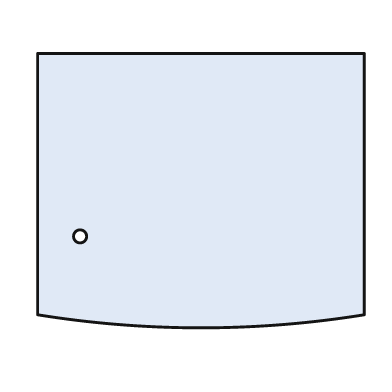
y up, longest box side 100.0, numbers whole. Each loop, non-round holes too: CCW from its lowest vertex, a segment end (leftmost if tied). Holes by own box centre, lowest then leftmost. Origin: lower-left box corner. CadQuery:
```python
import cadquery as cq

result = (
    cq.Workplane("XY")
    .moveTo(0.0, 4.0)
    .threePointArc((50.0, 0.0), (100.0, 4.0))
    .lineTo(100.0, 84.0)
    .lineTo(0.0, 84.0)
    .close()
    .moveTo(13.0, 28.0)
    .circle(2.0)
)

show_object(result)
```